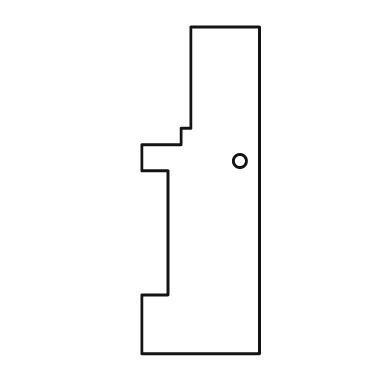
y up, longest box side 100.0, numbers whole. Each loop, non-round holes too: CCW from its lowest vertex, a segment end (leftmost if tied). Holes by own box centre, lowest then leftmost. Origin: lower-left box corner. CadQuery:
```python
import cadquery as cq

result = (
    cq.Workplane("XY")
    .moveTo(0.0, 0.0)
    .lineTo(36.0, 0.0)
    .lineTo(36.0, 100.0)
    .lineTo(15.0, 100.0)
    .lineTo(15.0, 69.0)
    .lineTo(12.0, 69.0)
    .lineTo(12.0, 64.0)
    .lineTo(0.0, 64.0)
    .lineTo(0.0, 56.0)
    .lineTo(8.0, 56.0)
    .lineTo(8.0, 18.0)
    .lineTo(0.0, 18.0)
    .close()
    .moveTo(30.0, 59.0)
    .circle(2.0)
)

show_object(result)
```